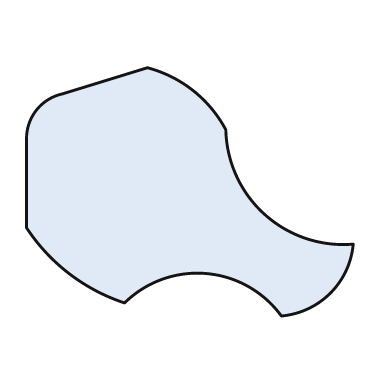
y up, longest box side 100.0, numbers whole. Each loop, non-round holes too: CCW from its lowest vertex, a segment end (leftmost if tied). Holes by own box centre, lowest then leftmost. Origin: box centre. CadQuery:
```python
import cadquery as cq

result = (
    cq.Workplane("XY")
    .moveTo(28.0, -38.0)
    .threePointArc((43.0, -31.0), (50.0, -16.0))
    .threePointArc((23.0, -7.0), (11.0, 19.0))
    .threePointArc((1.0, 31.0), (-13.0, 38.0))
    .lineTo(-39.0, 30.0)
    .threePointArc((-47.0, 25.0), (-50.0, 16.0))
    .lineTo(-50.0, -11.0)
    .threePointArc((-37.0, -25.0), (-20.0, -34.0))
    .threePointArc((5.0, -25.0), (28.0, -38.0))
    .close()
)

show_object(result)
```